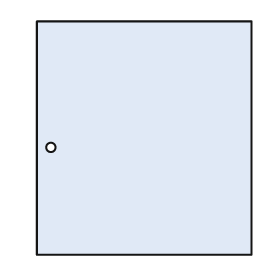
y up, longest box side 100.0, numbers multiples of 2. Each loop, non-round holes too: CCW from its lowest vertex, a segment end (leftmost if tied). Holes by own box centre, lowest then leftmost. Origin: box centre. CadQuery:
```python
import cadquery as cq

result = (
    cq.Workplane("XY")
    .moveTo(-46.0, -50.0)
    .lineTo(46.0, -50.0)
    .lineTo(46.0, 50.0)
    .lineTo(-46.0, 50.0)
    .close()
    .moveTo(-40.0, -4.0)
    .circle(2.0)
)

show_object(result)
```